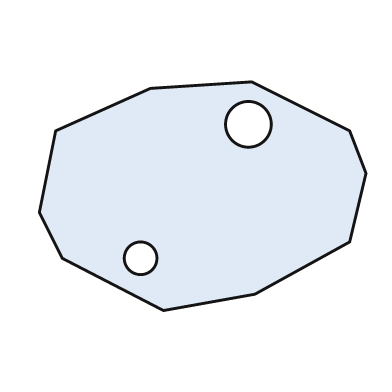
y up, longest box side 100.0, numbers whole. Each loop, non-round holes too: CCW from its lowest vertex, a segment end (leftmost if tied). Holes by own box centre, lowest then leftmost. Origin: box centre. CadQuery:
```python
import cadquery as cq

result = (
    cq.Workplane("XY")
    .moveTo(-12.0, -35.0)
    .lineTo(16.0, -30.0)
    .lineTo(45.0, -14.0)
    .lineTo(50.0, 7.0)
    .lineTo(45.0, 20.0)
    .lineTo(15.0, 35.0)
    .lineTo(-16.0, 33.0)
    .lineTo(-45.0, 20.0)
    .lineTo(-50.0, -5.0)
    .lineTo(-43.0, -19.0)
    .close()
    .moveTo(-19.0, -19.0)
    .circle(5.0)
    .moveTo(14.0, 22.0)
    .circle(7.0)
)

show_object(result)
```